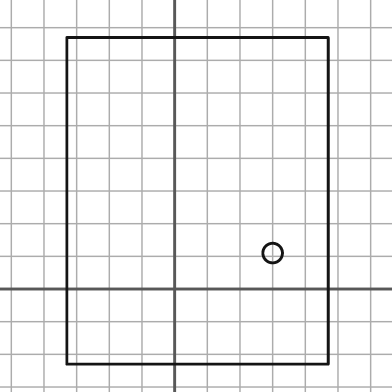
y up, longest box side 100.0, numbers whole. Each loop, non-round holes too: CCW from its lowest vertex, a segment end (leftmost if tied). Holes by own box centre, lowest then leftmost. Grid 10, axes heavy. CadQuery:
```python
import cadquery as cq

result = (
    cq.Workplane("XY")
    .moveTo(-33.0, -23.0)
    .lineTo(47.0, -23.0)
    .lineTo(47.0, 77.0)
    .lineTo(-33.0, 77.0)
    .close()
    .moveTo(30.0, 11.0)
    .circle(3.0)
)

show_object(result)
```